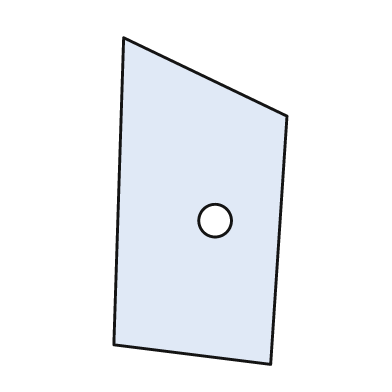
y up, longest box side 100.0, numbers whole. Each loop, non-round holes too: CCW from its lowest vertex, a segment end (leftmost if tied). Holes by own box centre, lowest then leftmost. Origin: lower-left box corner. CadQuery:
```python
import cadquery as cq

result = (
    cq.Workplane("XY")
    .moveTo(48.0, 0.0)
    .lineTo(53.0, 76.0)
    .lineTo(3.0, 100.0)
    .lineTo(0.0, 6.0)
    .close()
    .moveTo(31.0, 44.0)
    .circle(5.0)
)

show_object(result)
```